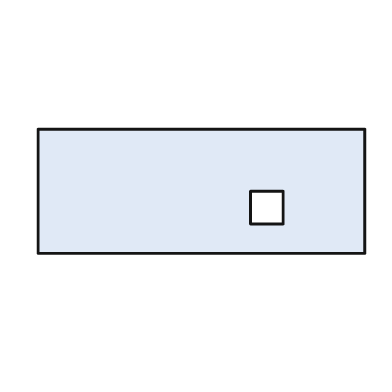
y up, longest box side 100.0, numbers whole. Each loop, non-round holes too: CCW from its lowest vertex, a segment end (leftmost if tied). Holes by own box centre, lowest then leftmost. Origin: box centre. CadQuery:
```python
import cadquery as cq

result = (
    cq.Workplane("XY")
    .moveTo(-50.0, -19.0)
    .lineTo(50.0, -19.0)
    .lineTo(50.0, 19.0)
    .lineTo(-50.0, 19.0)
    .close()
    .moveTo(15.0, -10.0)
    .lineTo(25.0, -10.0)
    .lineTo(25.0, 0.0)
    .lineTo(15.0, 0.0)
    .close()
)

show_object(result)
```